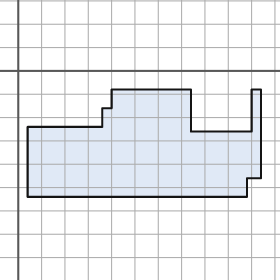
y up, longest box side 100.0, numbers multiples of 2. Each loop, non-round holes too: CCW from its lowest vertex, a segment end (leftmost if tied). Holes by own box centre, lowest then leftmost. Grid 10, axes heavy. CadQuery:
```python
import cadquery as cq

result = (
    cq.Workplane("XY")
    .moveTo(4.0, -54.0)
    .lineTo(98.0, -54.0)
    .lineTo(98.0, -46.0)
    .lineTo(104.0, -46.0)
    .lineTo(104.0, -8.0)
    .lineTo(100.0, -8.0)
    .lineTo(100.0, -26.0)
    .lineTo(74.0, -26.0)
    .lineTo(74.0, -8.0)
    .lineTo(40.0, -8.0)
    .lineTo(40.0, -16.0)
    .lineTo(36.0, -16.0)
    .lineTo(36.0, -24.0)
    .lineTo(4.0, -24.0)
    .close()
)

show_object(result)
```